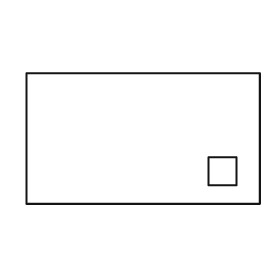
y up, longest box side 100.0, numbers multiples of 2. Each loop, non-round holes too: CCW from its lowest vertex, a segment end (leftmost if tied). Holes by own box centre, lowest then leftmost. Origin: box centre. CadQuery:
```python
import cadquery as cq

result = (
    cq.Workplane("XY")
    .moveTo(-50.0, -28.0)
    .lineTo(50.0, -28.0)
    .lineTo(50.0, 28.0)
    .lineTo(-50.0, 28.0)
    .close()
    .moveTo(28.0, -20.0)
    .lineTo(40.0, -20.0)
    .lineTo(40.0, -8.0)
    .lineTo(28.0, -8.0)
    .close()
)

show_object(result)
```